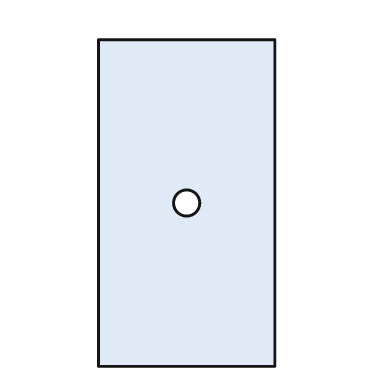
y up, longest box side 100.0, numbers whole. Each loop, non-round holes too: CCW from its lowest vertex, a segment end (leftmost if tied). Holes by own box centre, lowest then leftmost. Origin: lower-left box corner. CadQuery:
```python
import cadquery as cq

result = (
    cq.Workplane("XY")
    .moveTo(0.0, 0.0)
    .lineTo(54.0, 0.0)
    .lineTo(54.0, 100.0)
    .lineTo(0.0, 100.0)
    .close()
    .moveTo(27.0, 50.0)
    .circle(4.0)
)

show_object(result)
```